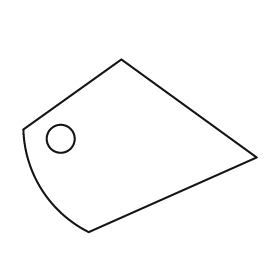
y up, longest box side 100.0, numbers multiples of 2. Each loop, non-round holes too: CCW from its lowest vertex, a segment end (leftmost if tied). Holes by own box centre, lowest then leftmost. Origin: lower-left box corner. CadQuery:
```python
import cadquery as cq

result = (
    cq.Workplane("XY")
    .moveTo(28.0, 0.0)
    .lineTo(100.0, 32.0)
    .lineTo(42.0, 74.0)
    .lineTo(0.0, 44.0)
    .threePointArc((8.0, 18.0), (28.0, 0.0))
    .close()
    .moveTo(16.0, 40.0)
    .circle(6.0)
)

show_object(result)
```